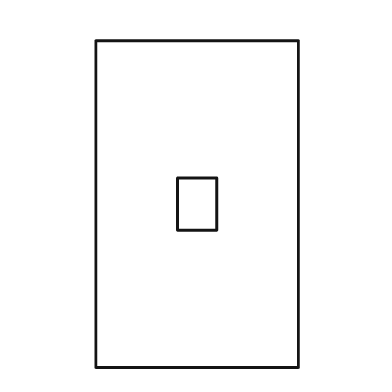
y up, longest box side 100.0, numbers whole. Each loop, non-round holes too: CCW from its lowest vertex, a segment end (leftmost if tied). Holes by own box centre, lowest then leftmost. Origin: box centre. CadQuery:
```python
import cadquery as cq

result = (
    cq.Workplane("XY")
    .moveTo(-31.0, -50.0)
    .lineTo(31.0, -50.0)
    .lineTo(31.0, 50.0)
    .lineTo(-31.0, 50.0)
    .close()
    .moveTo(-6.0, -8.0)
    .lineTo(6.0, -8.0)
    .lineTo(6.0, 8.0)
    .lineTo(-6.0, 8.0)
    .close()
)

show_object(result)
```